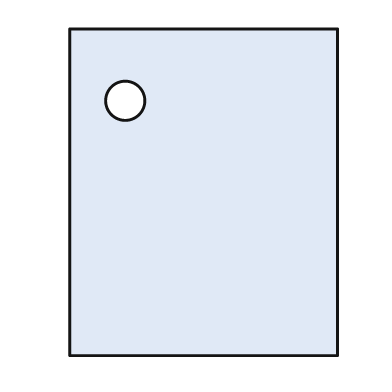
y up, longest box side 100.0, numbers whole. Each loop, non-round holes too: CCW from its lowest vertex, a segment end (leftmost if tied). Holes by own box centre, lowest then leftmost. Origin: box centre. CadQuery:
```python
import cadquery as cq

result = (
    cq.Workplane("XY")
    .moveTo(-41.0, -50.0)
    .lineTo(41.0, -50.0)
    .lineTo(41.0, 50.0)
    .lineTo(-41.0, 50.0)
    .close()
    .moveTo(-24.0, 28.0)
    .circle(6.0)
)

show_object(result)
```